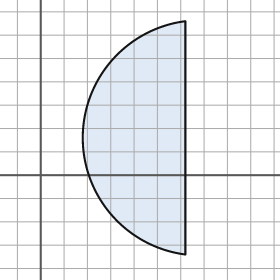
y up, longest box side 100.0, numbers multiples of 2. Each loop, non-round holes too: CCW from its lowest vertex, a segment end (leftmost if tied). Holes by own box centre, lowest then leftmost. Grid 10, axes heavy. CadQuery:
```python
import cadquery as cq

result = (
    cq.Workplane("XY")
    .moveTo(62.0, -34.0)
    .lineTo(62.0, 66.0)
    .threePointArc((18.0, 16.0), (62.0, -34.0))
    .close()
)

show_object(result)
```